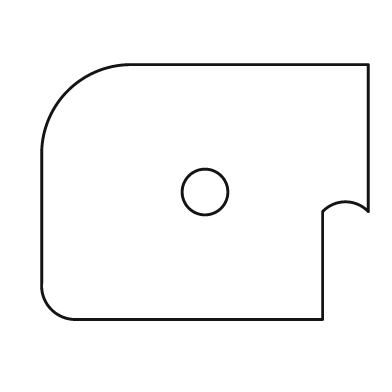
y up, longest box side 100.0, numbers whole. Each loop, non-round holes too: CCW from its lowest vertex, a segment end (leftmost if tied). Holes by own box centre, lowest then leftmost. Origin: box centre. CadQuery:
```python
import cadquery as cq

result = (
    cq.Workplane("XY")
    .moveTo(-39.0, -39.0)
    .lineTo(36.0, -39.0)
    .lineTo(36.0, -6.0)
    .threePointArc((43.0, -3.0), (50.0, -6.0))
    .lineTo(50.0, 39.0)
    .lineTo(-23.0, 39.0)
    .threePointArc((-42.0, 31.0), (-50.0, 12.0))
    .lineTo(-50.0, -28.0)
    .threePointArc((-47.0, -36.0), (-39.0, -39.0))
    .close()
    .moveTo(0.0, 0.0)
    .circle(7.0)
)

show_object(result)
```